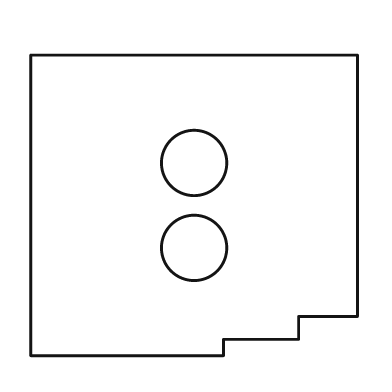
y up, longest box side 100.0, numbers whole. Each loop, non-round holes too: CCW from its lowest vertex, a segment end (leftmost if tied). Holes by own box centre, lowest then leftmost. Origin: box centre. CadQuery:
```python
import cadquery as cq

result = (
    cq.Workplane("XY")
    .moveTo(-50.0, -46.0)
    .lineTo(9.0, -46.0)
    .lineTo(9.0, -41.0)
    .lineTo(32.0, -41.0)
    .lineTo(32.0, -34.0)
    .lineTo(50.0, -34.0)
    .lineTo(50.0, 46.0)
    .lineTo(-50.0, 46.0)
    .close()
    .moveTo(0.0, -13.0)
    .circle(10.0)
    .moveTo(0.0, 13.0)
    .circle(10.0)
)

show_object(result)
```